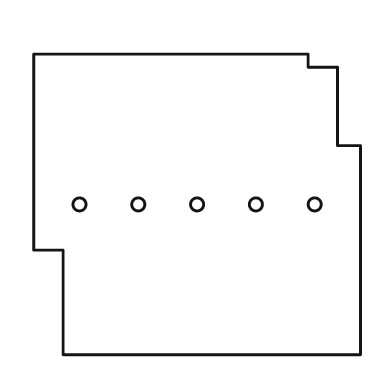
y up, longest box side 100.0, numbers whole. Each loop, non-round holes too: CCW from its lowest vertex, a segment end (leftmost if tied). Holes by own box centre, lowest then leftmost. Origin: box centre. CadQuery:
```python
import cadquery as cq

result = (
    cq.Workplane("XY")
    .moveTo(-41.0, -46.0)
    .lineTo(50.0, -46.0)
    .lineTo(50.0, 18.0)
    .lineTo(43.0, 18.0)
    .lineTo(43.0, 42.0)
    .lineTo(34.0, 42.0)
    .lineTo(34.0, 46.0)
    .lineTo(-50.0, 46.0)
    .lineTo(-50.0, -14.0)
    .lineTo(-41.0, -14.0)
    .close()
    .moveTo(-36.0, 0.0)
    .circle(2.0)
    .moveTo(-18.0, 0.0)
    .circle(2.0)
    .moveTo(0.0, 0.0)
    .circle(2.0)
    .moveTo(18.0, 0.0)
    .circle(2.0)
    .moveTo(36.0, 0.0)
    .circle(2.0)
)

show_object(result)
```